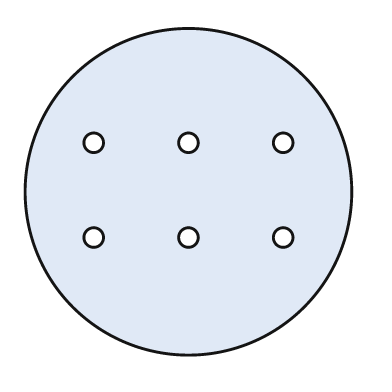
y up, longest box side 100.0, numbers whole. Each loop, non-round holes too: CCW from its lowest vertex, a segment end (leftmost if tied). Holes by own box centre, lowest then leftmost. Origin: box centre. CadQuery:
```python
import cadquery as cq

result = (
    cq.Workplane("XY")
    .moveTo(0.0, 0.0)
    .circle(50.0)
    .moveTo(-29.0, -14.0)
    .circle(3.0)
    .moveTo(0.0, -14.0)
    .circle(3.0)
    .moveTo(29.0, -14.0)
    .circle(3.0)
    .moveTo(-29.0, 15.0)
    .circle(3.0)
    .moveTo(0.0, 15.0)
    .circle(3.0)
    .moveTo(29.0, 15.0)
    .circle(3.0)
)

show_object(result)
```